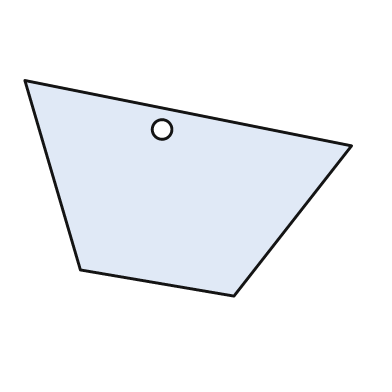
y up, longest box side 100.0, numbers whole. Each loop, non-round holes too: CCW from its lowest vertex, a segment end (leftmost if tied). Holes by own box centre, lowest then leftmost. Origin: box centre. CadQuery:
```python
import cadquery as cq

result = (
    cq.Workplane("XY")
    .moveTo(14.0, -33.0)
    .lineTo(50.0, 13.0)
    .lineTo(-50.0, 33.0)
    .lineTo(-33.0, -25.0)
    .close()
    .moveTo(-8.0, 18.0)
    .circle(3.0)
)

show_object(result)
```